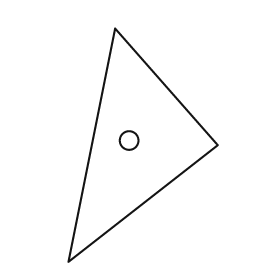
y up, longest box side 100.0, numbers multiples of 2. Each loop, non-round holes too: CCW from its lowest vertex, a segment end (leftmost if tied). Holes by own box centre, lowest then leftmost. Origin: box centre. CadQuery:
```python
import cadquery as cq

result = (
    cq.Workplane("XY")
    .moveTo(-32.0, -50.0)
    .lineTo(32.0, 0.0)
    .lineTo(-12.0, 50.0)
    .close()
    .moveTo(-6.0, 2.0)
    .circle(4.0)
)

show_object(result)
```